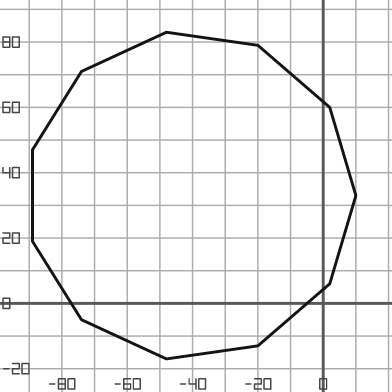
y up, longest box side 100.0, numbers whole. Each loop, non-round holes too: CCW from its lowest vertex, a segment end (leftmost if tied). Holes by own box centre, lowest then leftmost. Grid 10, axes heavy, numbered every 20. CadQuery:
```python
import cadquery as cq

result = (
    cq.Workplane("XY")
    .moveTo(-48.0, -17.0)
    .lineTo(-20.0, -13.0)
    .lineTo(2.0, 6.0)
    .lineTo(10.0, 33.0)
    .lineTo(2.0, 60.0)
    .lineTo(-20.0, 79.0)
    .lineTo(-48.0, 83.0)
    .lineTo(-74.0, 71.0)
    .lineTo(-89.0, 47.0)
    .lineTo(-89.0, 19.0)
    .lineTo(-74.0, -5.0)
    .close()
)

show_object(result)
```